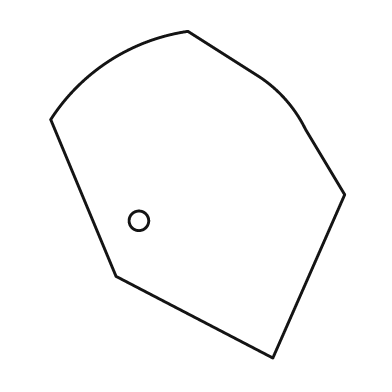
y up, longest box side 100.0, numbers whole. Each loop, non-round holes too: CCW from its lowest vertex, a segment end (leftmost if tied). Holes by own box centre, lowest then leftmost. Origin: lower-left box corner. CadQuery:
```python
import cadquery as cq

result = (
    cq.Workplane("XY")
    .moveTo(68.0, 0.0)
    .lineTo(90.0, 50.0)
    .lineTo(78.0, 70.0)
    .threePointArc((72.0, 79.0), (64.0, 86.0))
    .lineTo(42.0, 100.0)
    .threePointArc((18.0, 91.0), (0.0, 73.0))
    .lineTo(20.0, 25.0)
    .close()
    .moveTo(27.0, 42.0)
    .circle(3.0)
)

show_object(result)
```